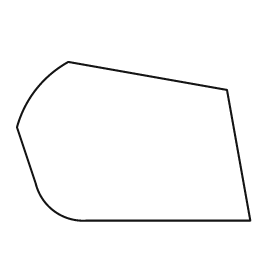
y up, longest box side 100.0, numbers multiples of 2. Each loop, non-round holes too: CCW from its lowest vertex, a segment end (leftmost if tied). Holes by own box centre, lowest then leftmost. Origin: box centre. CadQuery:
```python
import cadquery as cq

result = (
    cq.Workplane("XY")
    .moveTo(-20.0, -34.0)
    .lineTo(50.0, -34.0)
    .lineTo(40.0, 22.0)
    .lineTo(-28.0, 34.0)
    .threePointArc((-42.0, 22.0), (-50.0, 6.0))
    .lineTo(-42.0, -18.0)
    .threePointArc((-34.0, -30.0), (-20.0, -34.0))
    .close()
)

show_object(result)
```